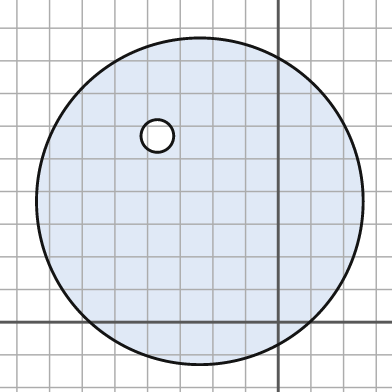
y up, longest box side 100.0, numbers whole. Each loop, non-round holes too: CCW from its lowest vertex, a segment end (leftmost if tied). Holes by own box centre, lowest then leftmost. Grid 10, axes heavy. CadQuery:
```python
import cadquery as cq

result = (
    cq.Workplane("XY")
    .moveTo(-24.0, 37.0)
    .circle(50.0)
    .moveTo(-37.0, 57.0)
    .circle(5.0)
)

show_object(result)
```